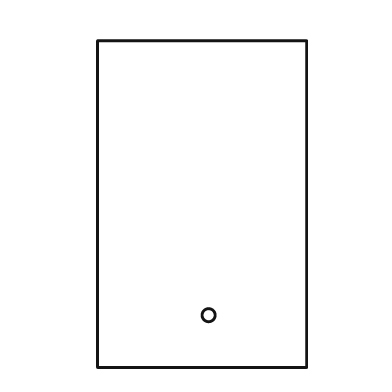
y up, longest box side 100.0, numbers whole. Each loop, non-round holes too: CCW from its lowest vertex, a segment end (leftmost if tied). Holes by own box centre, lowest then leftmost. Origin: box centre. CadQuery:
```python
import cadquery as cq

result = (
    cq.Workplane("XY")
    .moveTo(-32.0, -50.0)
    .lineTo(32.0, -50.0)
    .lineTo(32.0, 50.0)
    .lineTo(-32.0, 50.0)
    .close()
    .moveTo(2.0, -34.0)
    .circle(2.0)
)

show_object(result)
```